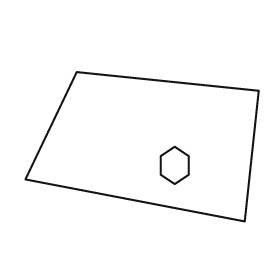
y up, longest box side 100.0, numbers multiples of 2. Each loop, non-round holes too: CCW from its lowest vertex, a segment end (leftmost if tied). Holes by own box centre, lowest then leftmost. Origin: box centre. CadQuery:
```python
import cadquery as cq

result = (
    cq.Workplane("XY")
    .moveTo(44.0, -32.0)
    .lineTo(50.0, 24.0)
    .lineTo(-28.0, 32.0)
    .lineTo(-50.0, -14.0)
    .close()
    .moveTo(14.0, -16.0)
    .lineTo(20.0, -12.0)
    .lineTo(20.0, -4.0)
    .lineTo(14.0, 0.0)
    .lineTo(8.0, -4.0)
    .lineTo(8.0, -12.0)
    .close()
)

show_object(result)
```